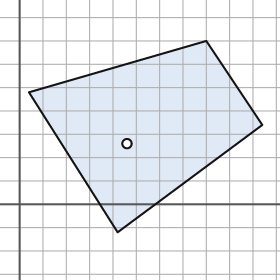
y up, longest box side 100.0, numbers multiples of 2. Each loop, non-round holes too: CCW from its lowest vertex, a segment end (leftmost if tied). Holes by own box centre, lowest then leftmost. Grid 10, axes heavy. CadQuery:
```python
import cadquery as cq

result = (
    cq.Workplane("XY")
    .moveTo(42.0, -12.0)
    .lineTo(104.0, 34.0)
    .lineTo(80.0, 70.0)
    .lineTo(4.0, 48.0)
    .close()
    .moveTo(46.0, 26.0)
    .circle(2.0)
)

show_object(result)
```